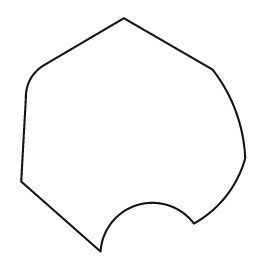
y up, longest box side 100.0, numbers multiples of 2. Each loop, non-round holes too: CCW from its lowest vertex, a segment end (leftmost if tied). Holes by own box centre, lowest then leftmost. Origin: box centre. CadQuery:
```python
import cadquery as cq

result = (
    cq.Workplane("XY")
    .moveTo(-14.0, -50.0)
    .threePointArc((2.0, -30.0), (26.0, -38.0))
    .threePointArc((40.0, -26.0), (48.0, -10.0))
    .threePointArc((44.0, 10.0), (34.0, 28.0))
    .lineTo(-4.0, 50.0)
    .lineTo(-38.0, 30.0)
    .threePointArc((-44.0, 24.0), (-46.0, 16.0))
    .lineTo(-48.0, -20.0)
    .close()
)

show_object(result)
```